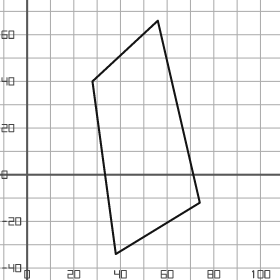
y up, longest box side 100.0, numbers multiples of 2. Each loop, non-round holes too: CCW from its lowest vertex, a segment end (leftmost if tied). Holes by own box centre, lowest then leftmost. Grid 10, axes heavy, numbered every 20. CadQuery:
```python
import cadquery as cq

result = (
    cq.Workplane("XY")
    .moveTo(38.0, -34.0)
    .lineTo(74.0, -12.0)
    .lineTo(56.0, 66.0)
    .lineTo(28.0, 40.0)
    .close()
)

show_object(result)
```